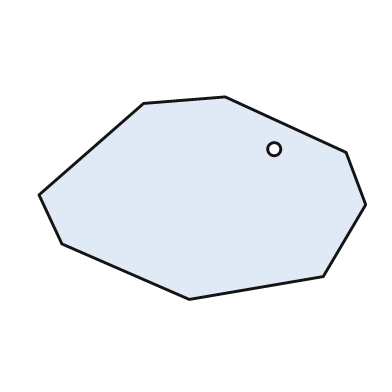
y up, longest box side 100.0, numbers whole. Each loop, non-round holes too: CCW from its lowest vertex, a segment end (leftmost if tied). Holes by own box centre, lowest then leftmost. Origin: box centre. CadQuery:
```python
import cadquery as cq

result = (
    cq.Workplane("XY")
    .moveTo(-4.0, -31.0)
    .lineTo(37.0, -24.0)
    .lineTo(50.0, -2.0)
    .lineTo(44.0, 14.0)
    .lineTo(7.0, 31.0)
    .lineTo(-18.0, 29.0)
    .lineTo(-50.0, 1.0)
    .lineTo(-43.0, -14.0)
    .close()
    .moveTo(22.0, 15.0)
    .circle(2.0)
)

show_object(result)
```